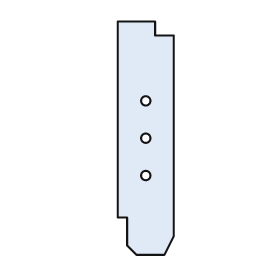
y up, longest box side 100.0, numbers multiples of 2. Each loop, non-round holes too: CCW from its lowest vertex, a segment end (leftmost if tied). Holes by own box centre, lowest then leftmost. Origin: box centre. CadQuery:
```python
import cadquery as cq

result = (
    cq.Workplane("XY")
    .moveTo(-4.0, -50.0)
    .lineTo(8.0, -50.0)
    .lineTo(12.0, -42.0)
    .lineTo(12.0, 44.0)
    .lineTo(4.0, 44.0)
    .lineTo(4.0, 50.0)
    .lineTo(-12.0, 50.0)
    .lineTo(-12.0, -34.0)
    .lineTo(-8.0, -34.0)
    .lineTo(-8.0, -46.0)
    .close()
    .moveTo(0.0, -16.0)
    .circle(2.0)
    .moveTo(0.0, 0.0)
    .circle(2.0)
    .moveTo(0.0, 16.0)
    .circle(2.0)
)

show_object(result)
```